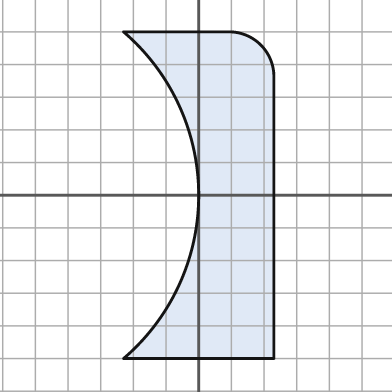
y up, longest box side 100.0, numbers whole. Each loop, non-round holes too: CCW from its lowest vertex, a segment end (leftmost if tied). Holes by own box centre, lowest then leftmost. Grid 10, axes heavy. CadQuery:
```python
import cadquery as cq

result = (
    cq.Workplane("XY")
    .moveTo(-23.0, -50.0)
    .lineTo(23.0, -50.0)
    .lineTo(23.0, 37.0)
    .threePointArc((19.0, 46.0), (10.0, 50.0))
    .lineTo(-23.0, 50.0)
    .threePointArc((0.0, 0.0), (-23.0, -50.0))
    .close()
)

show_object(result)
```